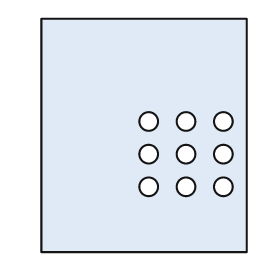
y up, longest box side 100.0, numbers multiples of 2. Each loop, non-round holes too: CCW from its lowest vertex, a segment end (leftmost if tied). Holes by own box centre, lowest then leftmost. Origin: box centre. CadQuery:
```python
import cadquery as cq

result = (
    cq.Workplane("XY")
    .moveTo(-44.0, -50.0)
    .lineTo(44.0, -50.0)
    .lineTo(44.0, 50.0)
    .lineTo(-44.0, 50.0)
    .close()
    .moveTo(2.0, -22.0)
    .circle(4.0)
    .moveTo(18.0, -22.0)
    .circle(4.0)
    .moveTo(34.0, -22.0)
    .circle(4.0)
    .moveTo(2.0, -8.0)
    .circle(4.0)
    .moveTo(18.0, -8.0)
    .circle(4.0)
    .moveTo(34.0, -8.0)
    .circle(4.0)
    .moveTo(2.0, 6.0)
    .circle(4.0)
    .moveTo(18.0, 6.0)
    .circle(4.0)
    .moveTo(34.0, 6.0)
    .circle(4.0)
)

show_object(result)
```